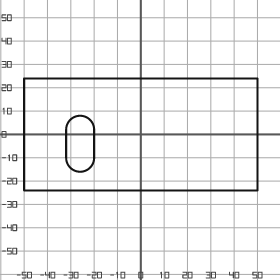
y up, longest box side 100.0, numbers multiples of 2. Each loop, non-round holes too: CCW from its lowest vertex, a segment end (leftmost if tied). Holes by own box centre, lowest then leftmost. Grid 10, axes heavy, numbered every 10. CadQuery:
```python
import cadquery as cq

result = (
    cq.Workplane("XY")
    .moveTo(-50.0, -24.0)
    .lineTo(50.0, -24.0)
    .lineTo(50.0, 24.0)
    .lineTo(-50.0, 24.0)
    .close()
    .moveTo(-32.0, -10.0)
    .threePointArc((-26.0, -16.0), (-20.0, -10.0))
    .lineTo(-20.0, 2.0)
    .threePointArc((-26.0, 8.0), (-32.0, 2.0))
    .close()
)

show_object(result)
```